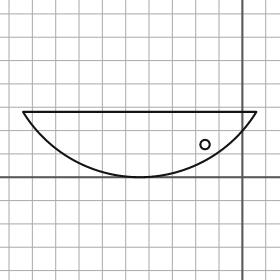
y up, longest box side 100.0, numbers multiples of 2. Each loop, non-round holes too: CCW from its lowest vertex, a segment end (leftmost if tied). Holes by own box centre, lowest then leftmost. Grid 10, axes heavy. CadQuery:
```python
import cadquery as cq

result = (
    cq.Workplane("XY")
    .moveTo(-94.0, 28.0)
    .threePointArc((-44.0, 0.0), (6.0, 28.0))
    .close()
    .moveTo(-16.0, 14.0)
    .circle(2.0)
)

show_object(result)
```